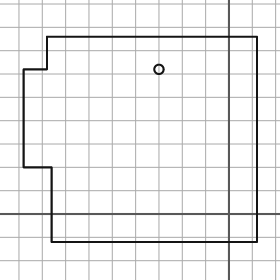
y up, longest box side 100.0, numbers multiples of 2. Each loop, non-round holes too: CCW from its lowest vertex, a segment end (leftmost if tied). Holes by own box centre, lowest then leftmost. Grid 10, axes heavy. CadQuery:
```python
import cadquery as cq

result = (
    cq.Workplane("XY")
    .moveTo(-76.0, -12.0)
    .lineTo(12.0, -12.0)
    .lineTo(12.0, 76.0)
    .lineTo(-78.0, 76.0)
    .lineTo(-78.0, 62.0)
    .lineTo(-88.0, 62.0)
    .lineTo(-88.0, 20.0)
    .lineTo(-76.0, 20.0)
    .close()
    .moveTo(-30.0, 62.0)
    .circle(2.0)
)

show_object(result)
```